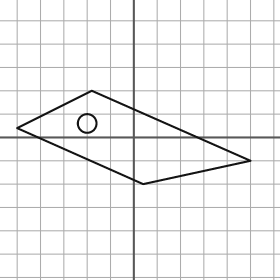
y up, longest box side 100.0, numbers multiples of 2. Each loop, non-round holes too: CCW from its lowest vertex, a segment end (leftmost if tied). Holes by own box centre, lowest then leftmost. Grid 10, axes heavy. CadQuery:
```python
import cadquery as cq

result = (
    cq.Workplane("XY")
    .moveTo(4.0, -20.0)
    .lineTo(50.0, -10.0)
    .lineTo(-18.0, 20.0)
    .lineTo(-50.0, 4.0)
    .close()
    .moveTo(-20.0, 6.0)
    .circle(4.0)
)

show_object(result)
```